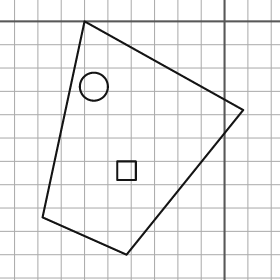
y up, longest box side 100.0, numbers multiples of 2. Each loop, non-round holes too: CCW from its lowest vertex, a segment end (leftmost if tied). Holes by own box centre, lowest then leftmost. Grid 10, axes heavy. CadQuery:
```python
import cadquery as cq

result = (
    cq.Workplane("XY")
    .moveTo(-42.0, -100.0)
    .lineTo(8.0, -38.0)
    .lineTo(-60.0, 0.0)
    .lineTo(-78.0, -84.0)
    .close()
    .moveTo(-46.0, -68.0)
    .lineTo(-38.0, -68.0)
    .lineTo(-38.0, -60.0)
    .lineTo(-46.0, -60.0)
    .close()
    .moveTo(-56.0, -28.0)
    .circle(6.0)
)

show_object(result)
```